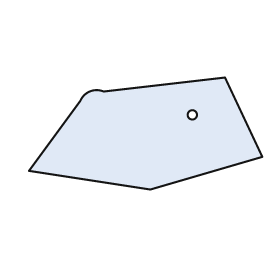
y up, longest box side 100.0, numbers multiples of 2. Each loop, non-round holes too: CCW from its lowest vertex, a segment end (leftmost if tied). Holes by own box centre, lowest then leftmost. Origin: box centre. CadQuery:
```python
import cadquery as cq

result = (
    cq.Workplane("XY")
    .moveTo(2.0, -24.0)
    .lineTo(50.0, -10.0)
    .lineTo(34.0, 24.0)
    .lineTo(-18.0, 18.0)
    .threePointArc((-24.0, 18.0), (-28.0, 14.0))
    .lineTo(-50.0, -16.0)
    .close()
    .moveTo(20.0, 8.0)
    .circle(2.0)
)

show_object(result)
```